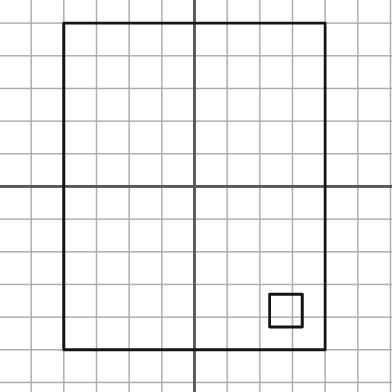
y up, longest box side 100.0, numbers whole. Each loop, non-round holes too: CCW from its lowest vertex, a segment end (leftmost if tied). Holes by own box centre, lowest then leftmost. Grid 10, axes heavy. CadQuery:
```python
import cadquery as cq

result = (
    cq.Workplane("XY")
    .moveTo(-40.0, -50.0)
    .lineTo(40.0, -50.0)
    .lineTo(40.0, 50.0)
    .lineTo(-40.0, 50.0)
    .close()
    .moveTo(23.0, -43.0)
    .lineTo(33.0, -43.0)
    .lineTo(33.0, -33.0)
    .lineTo(23.0, -33.0)
    .close()
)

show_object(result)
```